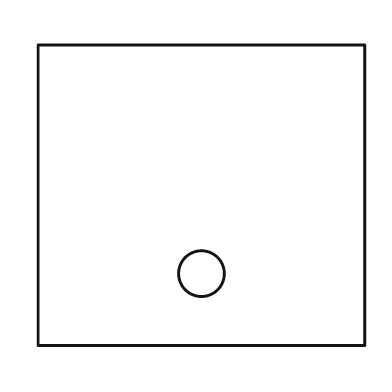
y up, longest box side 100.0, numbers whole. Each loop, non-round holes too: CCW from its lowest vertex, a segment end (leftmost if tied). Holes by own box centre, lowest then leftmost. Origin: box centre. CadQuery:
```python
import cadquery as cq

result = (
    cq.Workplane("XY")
    .moveTo(-50.0, -46.0)
    .lineTo(50.0, -46.0)
    .lineTo(50.0, 46.0)
    .lineTo(-50.0, 46.0)
    .close()
    .moveTo(0.0, -24.0)
    .circle(7.0)
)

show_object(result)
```